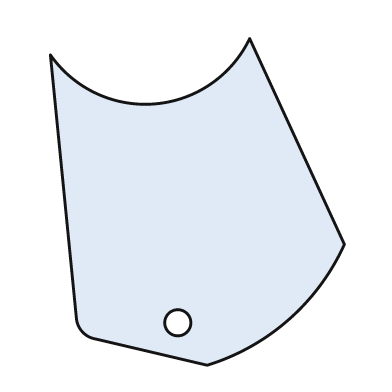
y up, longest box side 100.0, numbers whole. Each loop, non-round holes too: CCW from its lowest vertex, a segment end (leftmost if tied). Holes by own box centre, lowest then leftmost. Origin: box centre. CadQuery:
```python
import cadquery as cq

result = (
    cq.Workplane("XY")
    .moveTo(3.0, -50.0)
    .threePointArc((28.0, -36.0), (45.0, -13.0))
    .lineTo(16.0, 50.0)
    .threePointArc((-13.0, 30.0), (-45.0, 45.0))
    .lineTo(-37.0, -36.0)
    .threePointArc((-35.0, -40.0), (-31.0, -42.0))
    .close()
    .moveTo(-6.0, -37.0)
    .circle(4.0)
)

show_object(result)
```